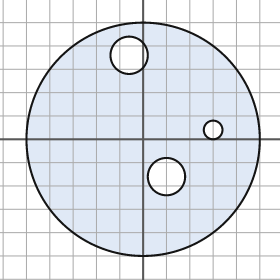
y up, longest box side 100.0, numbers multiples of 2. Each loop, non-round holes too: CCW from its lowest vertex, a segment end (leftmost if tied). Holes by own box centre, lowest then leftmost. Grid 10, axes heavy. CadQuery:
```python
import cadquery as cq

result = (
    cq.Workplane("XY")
    .moveTo(0.0, 0.0)
    .circle(50.0)
    .moveTo(10.0, -16.0)
    .circle(8.0)
    .moveTo(30.0, 4.0)
    .circle(4.0)
    .moveTo(-6.0, 36.0)
    .circle(8.0)
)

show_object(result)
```